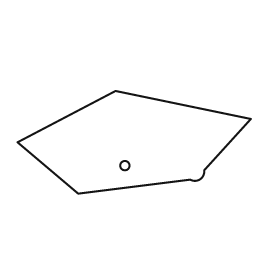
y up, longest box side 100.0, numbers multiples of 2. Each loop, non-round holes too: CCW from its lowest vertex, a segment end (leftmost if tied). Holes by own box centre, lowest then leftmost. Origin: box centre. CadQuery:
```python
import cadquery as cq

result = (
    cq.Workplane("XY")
    .moveTo(-24.0, -22.0)
    .lineTo(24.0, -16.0)
    .threePointArc((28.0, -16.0), (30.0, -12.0))
    .lineTo(50.0, 10.0)
    .lineTo(-8.0, 22.0)
    .lineTo(-50.0, 0.0)
    .close()
    .moveTo(-4.0, -10.0)
    .circle(2.0)
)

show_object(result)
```